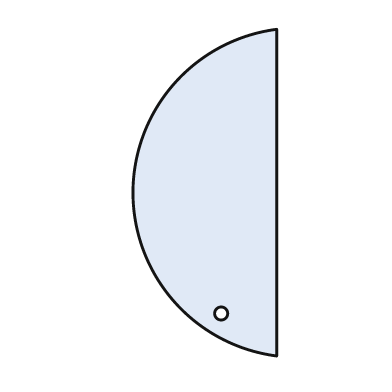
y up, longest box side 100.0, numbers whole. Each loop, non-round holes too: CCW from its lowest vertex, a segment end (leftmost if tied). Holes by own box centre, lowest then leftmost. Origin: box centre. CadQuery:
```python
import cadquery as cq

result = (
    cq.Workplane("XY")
    .moveTo(22.0, -50.0)
    .lineTo(22.0, 50.0)
    .threePointArc((-22.0, 0.0), (22.0, -50.0))
    .close()
    .moveTo(5.0, -37.0)
    .circle(2.0)
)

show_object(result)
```